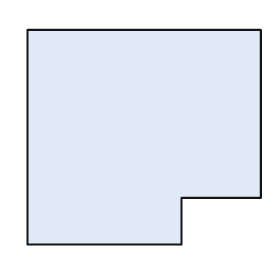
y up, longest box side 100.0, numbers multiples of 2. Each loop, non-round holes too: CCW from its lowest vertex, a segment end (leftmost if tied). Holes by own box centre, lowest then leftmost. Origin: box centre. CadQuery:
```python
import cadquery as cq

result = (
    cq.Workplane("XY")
    .moveTo(-50.0, -46.0)
    .lineTo(16.0, -46.0)
    .lineTo(16.0, -26.0)
    .lineTo(50.0, -26.0)
    .lineTo(50.0, 46.0)
    .lineTo(-50.0, 46.0)
    .close()
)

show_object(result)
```